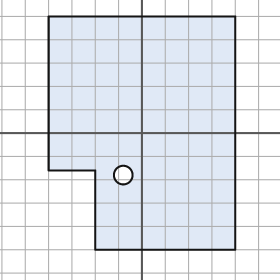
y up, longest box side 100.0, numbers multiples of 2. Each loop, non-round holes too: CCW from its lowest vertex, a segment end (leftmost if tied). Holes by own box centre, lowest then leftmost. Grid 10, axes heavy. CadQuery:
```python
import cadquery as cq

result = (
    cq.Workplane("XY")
    .moveTo(-20.0, -50.0)
    .lineTo(40.0, -50.0)
    .lineTo(40.0, 50.0)
    .lineTo(-40.0, 50.0)
    .lineTo(-40.0, -16.0)
    .lineTo(-20.0, -16.0)
    .close()
    .moveTo(-8.0, -18.0)
    .circle(4.0)
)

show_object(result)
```